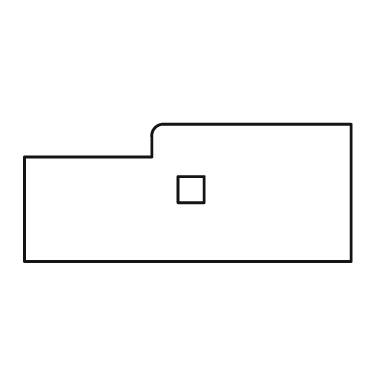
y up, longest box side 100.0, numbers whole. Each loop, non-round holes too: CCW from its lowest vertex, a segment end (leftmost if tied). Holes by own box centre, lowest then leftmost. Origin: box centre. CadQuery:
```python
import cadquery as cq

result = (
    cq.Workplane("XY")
    .moveTo(-50.0, -21.0)
    .lineTo(50.0, -21.0)
    .lineTo(50.0, 21.0)
    .lineTo(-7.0, 21.0)
    .threePointArc((-10.0, 20.0), (-11.0, 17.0))
    .lineTo(-11.0, 11.0)
    .lineTo(-50.0, 11.0)
    .close()
    .moveTo(-3.0, -3.0)
    .lineTo(5.0, -3.0)
    .lineTo(5.0, 5.0)
    .lineTo(-3.0, 5.0)
    .close()
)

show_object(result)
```